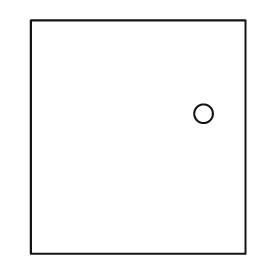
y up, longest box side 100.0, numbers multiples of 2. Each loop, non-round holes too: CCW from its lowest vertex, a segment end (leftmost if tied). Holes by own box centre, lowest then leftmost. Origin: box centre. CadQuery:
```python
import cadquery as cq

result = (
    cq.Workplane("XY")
    .moveTo(-46.0, -50.0)
    .lineTo(46.0, -50.0)
    .lineTo(46.0, 50.0)
    .lineTo(-46.0, 50.0)
    .close()
    .moveTo(28.0, 10.0)
    .circle(4.0)
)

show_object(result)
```